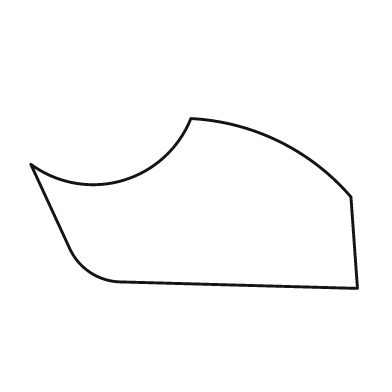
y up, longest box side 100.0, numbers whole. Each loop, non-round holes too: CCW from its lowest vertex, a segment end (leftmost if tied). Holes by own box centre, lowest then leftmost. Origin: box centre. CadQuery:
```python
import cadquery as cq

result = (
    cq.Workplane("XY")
    .moveTo(50.0, -26.0)
    .lineTo(48.0, 2.0)
    .threePointArc((26.0, 19.0), (-1.0, 26.0))
    .threePointArc((-22.0, 7.0), (-50.0, 12.0))
    .lineTo(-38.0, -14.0)
    .threePointArc((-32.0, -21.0), (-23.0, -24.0))
    .close()
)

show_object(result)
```